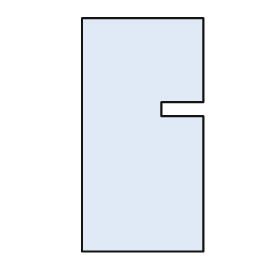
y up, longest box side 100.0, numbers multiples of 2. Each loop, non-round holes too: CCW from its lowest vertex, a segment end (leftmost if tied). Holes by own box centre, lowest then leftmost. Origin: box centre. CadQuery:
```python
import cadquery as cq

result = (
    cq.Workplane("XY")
    .moveTo(-26.0, -50.0)
    .lineTo(26.0, -50.0)
    .lineTo(26.0, 8.0)
    .lineTo(8.0, 8.0)
    .lineTo(8.0, 14.0)
    .lineTo(26.0, 14.0)
    .lineTo(26.0, 50.0)
    .lineTo(-26.0, 50.0)
    .close()
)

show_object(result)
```